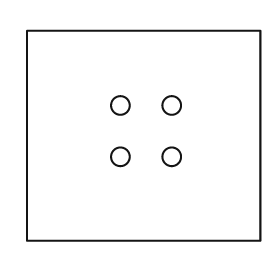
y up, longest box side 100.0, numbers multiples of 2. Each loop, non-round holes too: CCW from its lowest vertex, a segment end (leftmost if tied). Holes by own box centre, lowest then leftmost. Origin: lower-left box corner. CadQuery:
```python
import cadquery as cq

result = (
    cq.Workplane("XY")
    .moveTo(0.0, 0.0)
    .lineTo(100.0, 0.0)
    .lineTo(100.0, 90.0)
    .lineTo(0.0, 90.0)
    .close()
    .moveTo(40.0, 36.0)
    .circle(4.0)
    .moveTo(62.0, 36.0)
    .circle(4.0)
    .moveTo(40.0, 58.0)
    .circle(4.0)
    .moveTo(62.0, 58.0)
    .circle(4.0)
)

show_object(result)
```